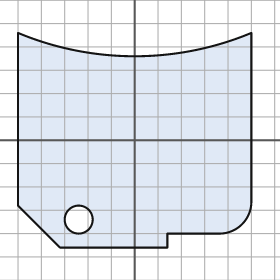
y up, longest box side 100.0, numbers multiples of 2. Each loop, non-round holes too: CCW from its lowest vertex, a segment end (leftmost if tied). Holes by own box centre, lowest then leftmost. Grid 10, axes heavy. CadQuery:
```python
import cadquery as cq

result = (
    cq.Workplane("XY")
    .moveTo(-32.0, -46.0)
    .lineTo(14.0, -46.0)
    .lineTo(14.0, -40.0)
    .lineTo(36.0, -40.0)
    .threePointArc((46.0, -36.0), (50.0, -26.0))
    .lineTo(50.0, 46.0)
    .threePointArc((0.0, 36.0), (-50.0, 46.0))
    .lineTo(-50.0, -28.0)
    .close()
    .moveTo(-24.0, -34.0)
    .circle(6.0)
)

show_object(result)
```